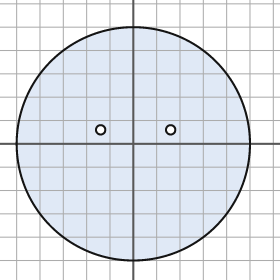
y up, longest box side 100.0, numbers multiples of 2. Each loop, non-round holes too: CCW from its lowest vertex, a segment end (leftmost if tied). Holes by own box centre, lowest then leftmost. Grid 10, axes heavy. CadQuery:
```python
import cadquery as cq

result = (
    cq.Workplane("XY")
    .moveTo(0.0, 0.0)
    .circle(50.0)
    .moveTo(-14.0, 6.0)
    .circle(2.0)
    .moveTo(16.0, 6.0)
    .circle(2.0)
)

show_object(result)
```